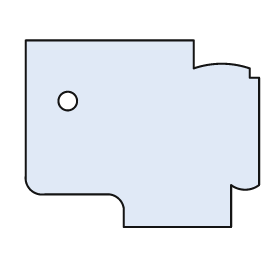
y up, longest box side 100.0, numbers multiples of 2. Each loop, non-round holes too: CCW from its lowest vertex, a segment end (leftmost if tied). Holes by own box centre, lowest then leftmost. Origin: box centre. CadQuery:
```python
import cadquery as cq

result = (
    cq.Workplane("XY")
    .moveTo(-8.0, -40.0)
    .lineTo(38.0, -40.0)
    .lineTo(38.0, -22.0)
    .threePointArc((44.0, -24.0), (50.0, -22.0))
    .lineTo(50.0, 24.0)
    .lineTo(46.0, 24.0)
    .lineTo(46.0, 28.0)
    .threePointArc((34.0, 30.0), (22.0, 28.0))
    .lineTo(22.0, 40.0)
    .lineTo(-50.0, 40.0)
    .lineTo(-50.0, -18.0)
    .threePointArc((-48.0, -24.0), (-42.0, -26.0))
    .lineTo(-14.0, -26.0)
    .threePointArc((-10.0, -28.0), (-8.0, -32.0))
    .close()
    .moveTo(-32.0, 14.0)
    .circle(4.0)
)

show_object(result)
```